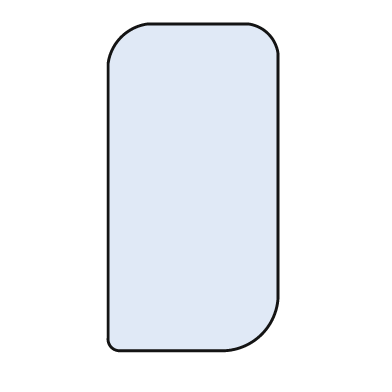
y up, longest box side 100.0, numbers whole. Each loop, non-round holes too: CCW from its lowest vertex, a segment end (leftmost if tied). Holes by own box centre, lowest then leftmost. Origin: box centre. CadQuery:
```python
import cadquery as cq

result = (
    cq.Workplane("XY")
    .moveTo(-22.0, -50.0)
    .lineTo(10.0, -50.0)
    .threePointArc((21.0, -45.0), (26.0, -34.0))
    .lineTo(26.0, 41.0)
    .threePointArc((23.0, 47.0), (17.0, 50.0))
    .lineTo(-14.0, 50.0)
    .threePointArc((-22.0, 46.0), (-26.0, 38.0))
    .lineTo(-26.0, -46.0)
    .threePointArc((-25.0, -49.0), (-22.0, -50.0))
    .close()
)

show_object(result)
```